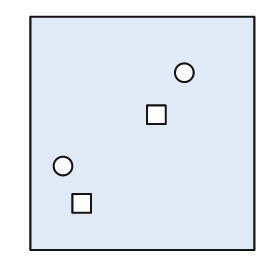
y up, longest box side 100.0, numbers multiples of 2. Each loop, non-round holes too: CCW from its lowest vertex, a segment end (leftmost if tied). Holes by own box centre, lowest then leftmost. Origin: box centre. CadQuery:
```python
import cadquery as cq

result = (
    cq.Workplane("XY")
    .moveTo(-48.0, -50.0)
    .lineTo(48.0, -50.0)
    .lineTo(48.0, 50.0)
    .lineTo(-48.0, 50.0)
    .close()
    .moveTo(-30.0, -34.0)
    .lineTo(-22.0, -34.0)
    .lineTo(-22.0, -26.0)
    .lineTo(-30.0, -26.0)
    .close()
    .moveTo(-34.0, -14.0)
    .circle(4.0)
    .moveTo(2.0, 4.0)
    .lineTo(10.0, 4.0)
    .lineTo(10.0, 12.0)
    .lineTo(2.0, 12.0)
    .close()
    .moveTo(18.0, 26.0)
    .circle(4.0)
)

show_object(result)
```